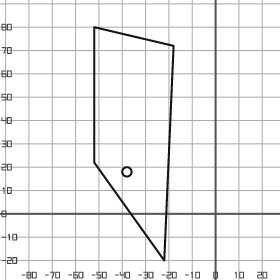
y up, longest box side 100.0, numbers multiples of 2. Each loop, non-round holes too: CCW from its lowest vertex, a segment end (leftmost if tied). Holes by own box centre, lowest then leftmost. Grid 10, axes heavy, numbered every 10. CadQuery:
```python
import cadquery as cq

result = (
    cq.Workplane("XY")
    .moveTo(-22.0, -20.0)
    .lineTo(-18.0, 72.0)
    .lineTo(-52.0, 80.0)
    .lineTo(-52.0, 22.0)
    .close()
    .moveTo(-38.0, 18.0)
    .circle(2.0)
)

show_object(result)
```